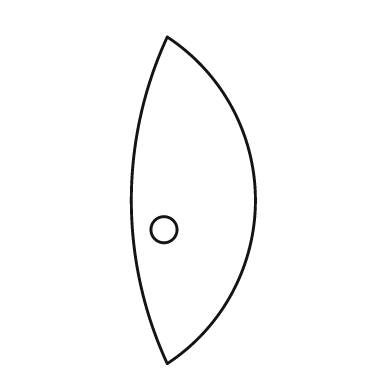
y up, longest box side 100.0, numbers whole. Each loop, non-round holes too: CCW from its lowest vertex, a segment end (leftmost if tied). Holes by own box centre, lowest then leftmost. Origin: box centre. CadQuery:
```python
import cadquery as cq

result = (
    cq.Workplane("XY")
    .moveTo(-8.0, -50.0)
    .threePointArc((19.0, 0.0), (-8.0, 50.0))
    .threePointArc((-19.0, 0.0), (-8.0, -50.0))
    .close()
    .moveTo(-9.0, -9.0)
    .circle(4.0)
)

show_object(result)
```